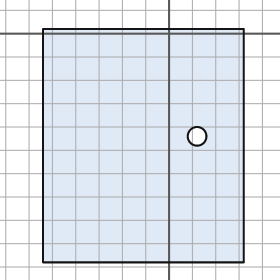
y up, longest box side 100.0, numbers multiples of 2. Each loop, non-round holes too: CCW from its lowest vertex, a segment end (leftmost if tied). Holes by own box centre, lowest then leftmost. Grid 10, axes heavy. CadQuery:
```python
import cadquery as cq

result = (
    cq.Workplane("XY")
    .moveTo(-54.0, -98.0)
    .lineTo(32.0, -98.0)
    .lineTo(32.0, 2.0)
    .lineTo(-54.0, 2.0)
    .close()
    .moveTo(12.0, -44.0)
    .circle(4.0)
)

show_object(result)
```